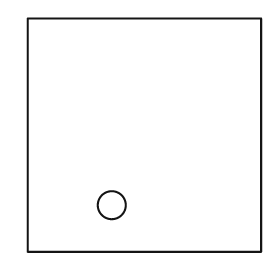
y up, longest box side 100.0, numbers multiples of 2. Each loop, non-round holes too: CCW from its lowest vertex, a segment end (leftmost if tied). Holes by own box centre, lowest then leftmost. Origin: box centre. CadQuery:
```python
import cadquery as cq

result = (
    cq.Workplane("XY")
    .moveTo(-50.0, -50.0)
    .lineTo(50.0, -50.0)
    .lineTo(50.0, 50.0)
    .lineTo(-50.0, 50.0)
    .close()
    .moveTo(-14.0, -30.0)
    .circle(6.0)
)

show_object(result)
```